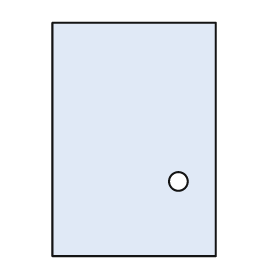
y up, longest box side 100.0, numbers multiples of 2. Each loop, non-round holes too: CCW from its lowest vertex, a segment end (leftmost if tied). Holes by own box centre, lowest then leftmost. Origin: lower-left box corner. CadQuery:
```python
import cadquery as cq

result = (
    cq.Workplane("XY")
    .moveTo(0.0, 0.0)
    .lineTo(70.0, 0.0)
    .lineTo(70.0, 100.0)
    .lineTo(0.0, 100.0)
    .close()
    .moveTo(54.0, 32.0)
    .circle(4.0)
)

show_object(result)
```